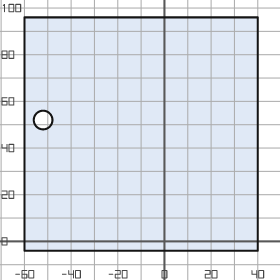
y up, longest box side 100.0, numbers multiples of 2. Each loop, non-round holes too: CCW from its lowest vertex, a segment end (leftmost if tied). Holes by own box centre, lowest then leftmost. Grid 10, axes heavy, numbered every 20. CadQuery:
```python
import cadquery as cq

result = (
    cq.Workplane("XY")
    .moveTo(-60.0, -4.0)
    .lineTo(40.0, -4.0)
    .lineTo(40.0, 96.0)
    .lineTo(-60.0, 96.0)
    .close()
    .moveTo(-52.0, 52.0)
    .circle(4.0)
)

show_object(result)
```